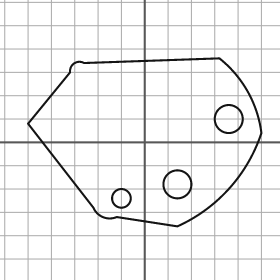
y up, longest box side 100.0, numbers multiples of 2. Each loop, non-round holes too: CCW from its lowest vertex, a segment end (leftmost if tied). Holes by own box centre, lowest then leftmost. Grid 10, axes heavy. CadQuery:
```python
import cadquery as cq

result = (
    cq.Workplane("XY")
    .moveTo(14.0, -36.0)
    .threePointArc((36.0, -20.0), (50.0, 4.0))
    .threePointArc((44.0, 22.0), (32.0, 36.0))
    .lineTo(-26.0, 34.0)
    .threePointArc((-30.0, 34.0), (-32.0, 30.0))
    .lineTo(-50.0, 8.0)
    .lineTo(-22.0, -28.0)
    .threePointArc((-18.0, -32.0), (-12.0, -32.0))
    .close()
    .moveTo(-10.0, -24.0)
    .circle(4.0)
    .moveTo(14.0, -18.0)
    .circle(6.0)
    .moveTo(36.0, 10.0)
    .circle(6.0)
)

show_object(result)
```